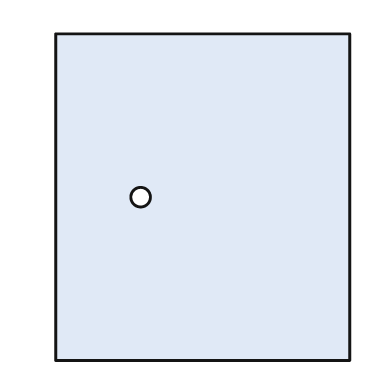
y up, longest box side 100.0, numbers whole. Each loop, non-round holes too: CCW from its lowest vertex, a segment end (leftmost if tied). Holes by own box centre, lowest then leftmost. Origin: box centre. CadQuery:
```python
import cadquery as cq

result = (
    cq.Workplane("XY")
    .moveTo(-45.0, -50.0)
    .lineTo(45.0, -50.0)
    .lineTo(45.0, 50.0)
    .lineTo(-45.0, 50.0)
    .close()
    .moveTo(-19.0, 0.0)
    .circle(3.0)
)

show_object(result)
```